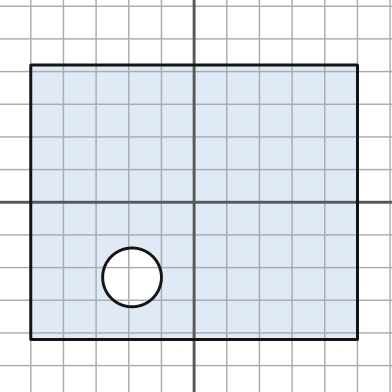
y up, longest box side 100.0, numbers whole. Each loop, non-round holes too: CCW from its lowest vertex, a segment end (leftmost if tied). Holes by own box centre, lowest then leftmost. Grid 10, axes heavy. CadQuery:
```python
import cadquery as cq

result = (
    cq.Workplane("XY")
    .moveTo(-50.0, -42.0)
    .lineTo(50.0, -42.0)
    .lineTo(50.0, 42.0)
    .lineTo(-50.0, 42.0)
    .close()
    .moveTo(-19.0, -23.0)
    .circle(9.0)
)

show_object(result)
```